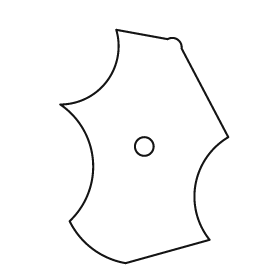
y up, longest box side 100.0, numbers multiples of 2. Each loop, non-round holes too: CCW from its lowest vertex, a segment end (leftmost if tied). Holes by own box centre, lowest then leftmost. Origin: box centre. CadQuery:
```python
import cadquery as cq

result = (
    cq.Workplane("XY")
    .moveTo(-8.0, -50.0)
    .lineTo(28.0, -40.0)
    .threePointArc((22.0, -16.0), (36.0, 4.0))
    .lineTo(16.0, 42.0)
    .threePointArc((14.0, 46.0), (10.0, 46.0))
    .lineTo(-12.0, 50.0)
    .threePointArc((-16.0, 28.0), (-36.0, 18.0))
    .threePointArc((-22.0, -6.0), (-32.0, -32.0))
    .threePointArc((-22.0, -44.0), (-8.0, -50.0))
    .close()
    .moveTo(0.0, 0.0)
    .circle(4.0)
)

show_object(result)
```